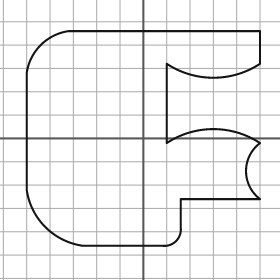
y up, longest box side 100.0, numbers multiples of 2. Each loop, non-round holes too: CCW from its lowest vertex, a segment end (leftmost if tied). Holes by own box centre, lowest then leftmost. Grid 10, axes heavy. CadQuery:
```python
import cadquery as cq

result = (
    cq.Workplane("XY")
    .moveTo(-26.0, -46.0)
    .lineTo(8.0, -46.0)
    .threePointArc((14.0, -44.0), (16.0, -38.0))
    .lineTo(16.0, -26.0)
    .lineTo(50.0, -26.0)
    .threePointArc((44.0, -14.0), (50.0, -2.0))
    .threePointArc((30.0, 4.0), (10.0, -2.0))
    .lineTo(10.0, 32.0)
    .threePointArc((30.0, 26.0), (50.0, 32.0))
    .lineTo(50.0, 46.0)
    .lineTo(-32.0, 46.0)
    .threePointArc((-44.0, 40.0), (-50.0, 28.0))
    .lineTo(-50.0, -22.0)
    .threePointArc((-42.0, -38.0), (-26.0, -46.0))
    .close()
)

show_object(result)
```